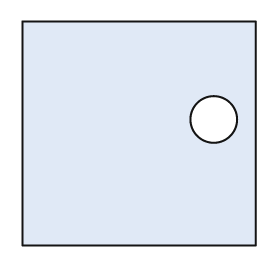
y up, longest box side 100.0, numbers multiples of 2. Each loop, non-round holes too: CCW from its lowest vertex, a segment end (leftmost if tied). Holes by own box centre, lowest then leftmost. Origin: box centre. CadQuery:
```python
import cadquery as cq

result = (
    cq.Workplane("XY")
    .moveTo(-50.0, -48.0)
    .lineTo(50.0, -48.0)
    .lineTo(50.0, 48.0)
    .lineTo(-50.0, 48.0)
    .close()
    .moveTo(32.0, 6.0)
    .circle(10.0)
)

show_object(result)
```